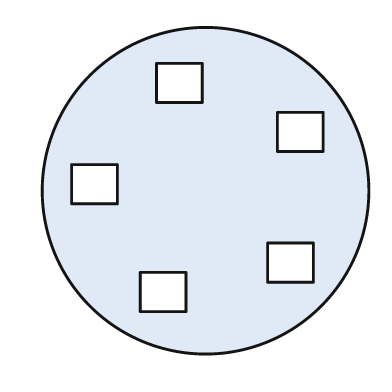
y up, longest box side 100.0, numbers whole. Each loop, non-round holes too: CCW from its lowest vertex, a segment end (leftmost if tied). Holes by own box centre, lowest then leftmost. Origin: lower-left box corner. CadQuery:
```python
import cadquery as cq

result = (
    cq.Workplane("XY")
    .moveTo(50.0, 50.0)
    .circle(50.0)
    .moveTo(30.0, 13.0)
    .lineTo(44.0, 13.0)
    .lineTo(44.0, 25.0)
    .lineTo(30.0, 25.0)
    .close()
    .moveTo(69.0, 22.0)
    .lineTo(83.0, 22.0)
    .lineTo(83.0, 34.0)
    .lineTo(69.0, 34.0)
    .close()
    .moveTo(9.0, 46.0)
    .lineTo(23.0, 46.0)
    .lineTo(23.0, 58.0)
    .lineTo(9.0, 58.0)
    .close()
    .moveTo(72.0, 62.0)
    .lineTo(86.0, 62.0)
    .lineTo(86.0, 74.0)
    .lineTo(72.0, 74.0)
    .close()
    .moveTo(35.0, 77.0)
    .lineTo(49.0, 77.0)
    .lineTo(49.0, 89.0)
    .lineTo(35.0, 89.0)
    .close()
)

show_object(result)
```